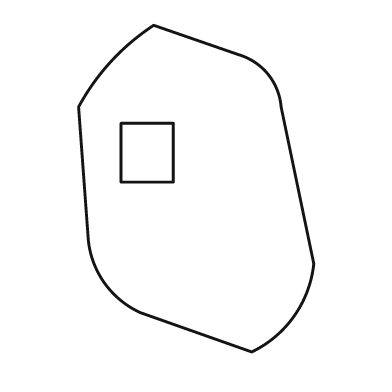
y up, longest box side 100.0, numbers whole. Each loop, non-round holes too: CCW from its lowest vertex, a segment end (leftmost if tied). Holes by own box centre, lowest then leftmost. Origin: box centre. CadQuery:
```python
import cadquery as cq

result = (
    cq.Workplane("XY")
    .moveTo(17.0, -50.0)
    .threePointArc((30.0, -39.0), (36.0, -23.0))
    .lineTo(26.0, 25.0)
    .threePointArc((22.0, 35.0), (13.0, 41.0))
    .lineTo(-13.0, 50.0)
    .threePointArc((-26.0, 39.0), (-36.0, 25.0))
    .lineTo(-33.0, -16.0)
    .threePointArc((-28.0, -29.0), (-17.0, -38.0))
    .close()
    .moveTo(-23.0, 2.0)
    .lineTo(-7.0, 2.0)
    .lineTo(-7.0, 20.0)
    .lineTo(-23.0, 20.0)
    .close()
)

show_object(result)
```